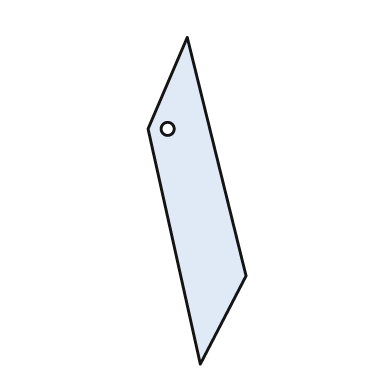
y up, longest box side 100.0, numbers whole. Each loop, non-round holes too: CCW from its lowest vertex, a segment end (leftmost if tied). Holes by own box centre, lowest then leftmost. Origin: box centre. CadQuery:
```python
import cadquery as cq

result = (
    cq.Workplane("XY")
    .moveTo(1.0, -50.0)
    .lineTo(15.0, -23.0)
    .lineTo(-3.0, 50.0)
    .lineTo(-15.0, 22.0)
    .close()
    .moveTo(-9.0, 22.0)
    .circle(2.0)
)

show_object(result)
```